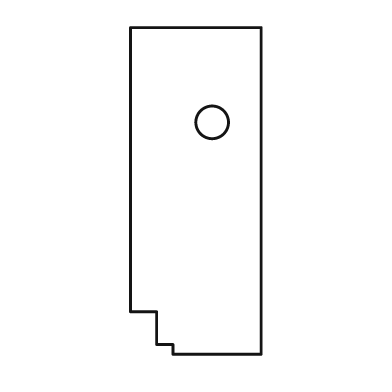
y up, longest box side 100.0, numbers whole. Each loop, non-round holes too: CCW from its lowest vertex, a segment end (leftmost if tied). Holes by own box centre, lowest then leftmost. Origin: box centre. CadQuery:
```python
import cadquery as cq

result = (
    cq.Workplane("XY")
    .moveTo(-7.0, -50.0)
    .lineTo(20.0, -50.0)
    .lineTo(20.0, 50.0)
    .lineTo(-20.0, 50.0)
    .lineTo(-20.0, -37.0)
    .lineTo(-12.0, -37.0)
    .lineTo(-12.0, -47.0)
    .lineTo(-7.0, -47.0)
    .close()
    .moveTo(5.0, 21.0)
    .circle(5.0)
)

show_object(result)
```